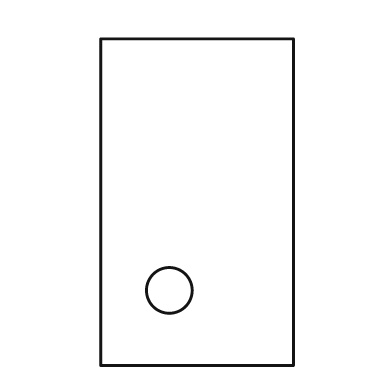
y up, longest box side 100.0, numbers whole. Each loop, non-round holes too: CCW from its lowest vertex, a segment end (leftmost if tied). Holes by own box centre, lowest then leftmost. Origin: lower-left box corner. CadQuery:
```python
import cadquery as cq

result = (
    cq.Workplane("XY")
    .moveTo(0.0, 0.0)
    .lineTo(59.0, 0.0)
    .lineTo(59.0, 100.0)
    .lineTo(0.0, 100.0)
    .close()
    .moveTo(21.0, 23.0)
    .circle(7.0)
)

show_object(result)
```